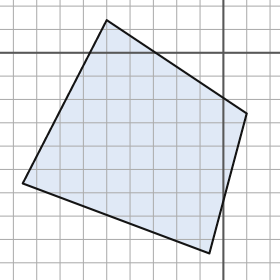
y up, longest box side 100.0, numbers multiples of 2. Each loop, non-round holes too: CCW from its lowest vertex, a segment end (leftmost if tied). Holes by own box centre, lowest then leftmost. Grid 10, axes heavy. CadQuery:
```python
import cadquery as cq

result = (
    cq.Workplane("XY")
    .moveTo(-6.0, -86.0)
    .lineTo(10.0, -26.0)
    .lineTo(-50.0, 14.0)
    .lineTo(-86.0, -56.0)
    .close()
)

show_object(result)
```